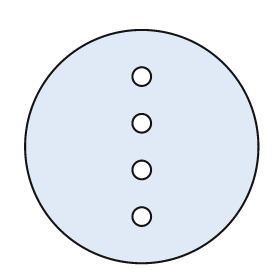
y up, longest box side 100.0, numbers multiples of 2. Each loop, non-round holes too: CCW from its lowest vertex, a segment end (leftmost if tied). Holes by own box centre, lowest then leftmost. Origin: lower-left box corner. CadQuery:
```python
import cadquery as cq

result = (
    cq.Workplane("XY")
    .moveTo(50.0, 50.0)
    .circle(50.0)
    .moveTo(50.0, 20.0)
    .circle(4.0)
    .moveTo(50.0, 40.0)
    .circle(4.0)
    .moveTo(50.0, 60.0)
    .circle(4.0)
    .moveTo(50.0, 80.0)
    .circle(4.0)
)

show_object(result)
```